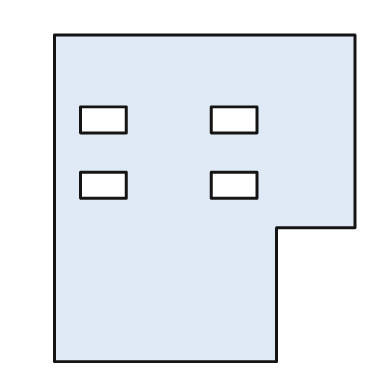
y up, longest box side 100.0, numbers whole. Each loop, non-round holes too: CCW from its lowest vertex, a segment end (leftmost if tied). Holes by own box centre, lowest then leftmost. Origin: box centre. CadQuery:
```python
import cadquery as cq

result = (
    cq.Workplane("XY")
    .moveTo(-46.0, -50.0)
    .lineTo(22.0, -50.0)
    .lineTo(22.0, -9.0)
    .lineTo(46.0, -9.0)
    .lineTo(46.0, 50.0)
    .lineTo(-46.0, 50.0)
    .close()
    .moveTo(-38.0, 0.0)
    .lineTo(-24.0, 0.0)
    .lineTo(-24.0, 8.0)
    .lineTo(-38.0, 8.0)
    .close()
    .moveTo(2.0, 0.0)
    .lineTo(16.0, 0.0)
    .lineTo(16.0, 8.0)
    .lineTo(2.0, 8.0)
    .close()
    .moveTo(-38.0, 20.0)
    .lineTo(-24.0, 20.0)
    .lineTo(-24.0, 28.0)
    .lineTo(-38.0, 28.0)
    .close()
    .moveTo(2.0, 20.0)
    .lineTo(16.0, 20.0)
    .lineTo(16.0, 28.0)
    .lineTo(2.0, 28.0)
    .close()
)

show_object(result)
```